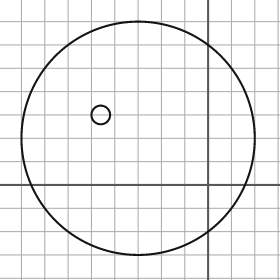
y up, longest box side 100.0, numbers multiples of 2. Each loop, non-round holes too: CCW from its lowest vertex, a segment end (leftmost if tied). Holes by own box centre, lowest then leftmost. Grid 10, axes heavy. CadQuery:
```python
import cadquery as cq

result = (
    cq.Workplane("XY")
    .moveTo(-30.0, 20.0)
    .circle(50.0)
    .moveTo(-46.0, 30.0)
    .circle(4.0)
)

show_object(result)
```